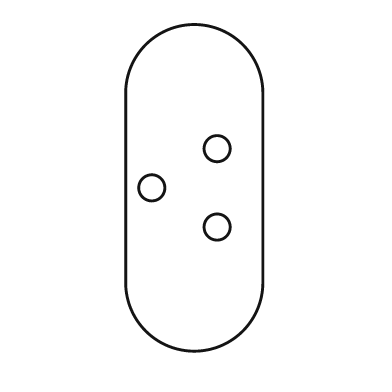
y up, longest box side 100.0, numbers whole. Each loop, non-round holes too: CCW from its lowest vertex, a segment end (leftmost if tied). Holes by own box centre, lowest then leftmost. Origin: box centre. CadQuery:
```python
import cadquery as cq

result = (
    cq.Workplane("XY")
    .moveTo(-21.0, -29.0)
    .threePointArc((0.0, -50.0), (21.0, -29.0))
    .lineTo(21.0, 29.0)
    .threePointArc((0.0, 50.0), (-21.0, 29.0))
    .close()
    .moveTo(7.0, -12.0)
    .circle(4.0)
    .moveTo(-13.0, 0.0)
    .circle(4.0)
    .moveTo(7.0, 12.0)
    .circle(4.0)
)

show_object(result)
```